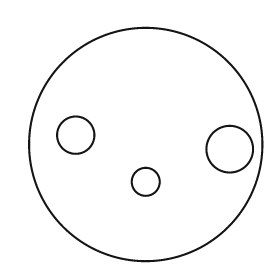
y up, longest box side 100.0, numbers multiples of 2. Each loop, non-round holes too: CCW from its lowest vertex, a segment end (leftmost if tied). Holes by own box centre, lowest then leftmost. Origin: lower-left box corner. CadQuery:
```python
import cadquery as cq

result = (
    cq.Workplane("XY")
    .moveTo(50.0, 50.0)
    .circle(50.0)
    .moveTo(50.0, 34.0)
    .circle(6.0)
    .moveTo(86.0, 48.0)
    .circle(10.0)
    .moveTo(20.0, 54.0)
    .circle(8.0)
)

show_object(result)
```